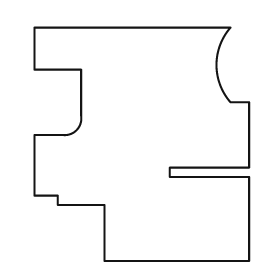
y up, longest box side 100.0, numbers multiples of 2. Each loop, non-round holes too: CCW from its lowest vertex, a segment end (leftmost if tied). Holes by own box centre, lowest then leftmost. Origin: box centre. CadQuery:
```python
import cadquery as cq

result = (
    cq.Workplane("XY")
    .moveTo(-16.0, -50.0)
    .lineTo(46.0, -50.0)
    .lineTo(46.0, -14.0)
    .lineTo(12.0, -14.0)
    .lineTo(12.0, -10.0)
    .lineTo(46.0, -10.0)
    .lineTo(46.0, 18.0)
    .lineTo(38.0, 18.0)
    .threePointArc((32.0, 34.0), (38.0, 50.0))
    .lineTo(-46.0, 50.0)
    .lineTo(-46.0, 32.0)
    .lineTo(-26.0, 32.0)
    .lineTo(-26.0, 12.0)
    .threePointArc((-28.0, 6.0), (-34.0, 4.0))
    .lineTo(-46.0, 4.0)
    .lineTo(-46.0, -22.0)
    .lineTo(-36.0, -22.0)
    .lineTo(-36.0, -26.0)
    .lineTo(-16.0, -26.0)
    .close()
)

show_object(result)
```